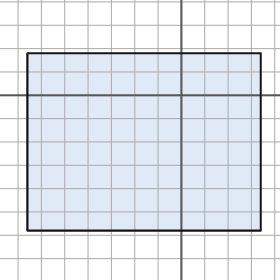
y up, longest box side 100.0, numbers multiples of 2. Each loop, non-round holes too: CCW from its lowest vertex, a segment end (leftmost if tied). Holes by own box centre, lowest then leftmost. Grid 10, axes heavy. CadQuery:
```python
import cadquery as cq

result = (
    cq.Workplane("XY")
    .moveTo(-66.0, -58.0)
    .lineTo(34.0, -58.0)
    .lineTo(34.0, 18.0)
    .lineTo(-66.0, 18.0)
    .close()
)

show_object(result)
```